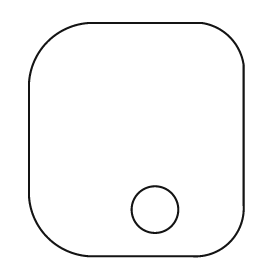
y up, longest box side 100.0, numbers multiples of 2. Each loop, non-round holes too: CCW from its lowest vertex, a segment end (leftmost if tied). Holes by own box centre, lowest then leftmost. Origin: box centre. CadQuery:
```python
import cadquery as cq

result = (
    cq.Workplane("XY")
    .moveTo(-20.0, -50.0)
    .lineTo(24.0, -50.0)
    .threePointArc((40.0, -44.0), (46.0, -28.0))
    .lineTo(46.0, 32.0)
    .threePointArc((40.0, 44.0), (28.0, 50.0))
    .lineTo(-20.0, 50.0)
    .threePointArc((-38.0, 42.0), (-46.0, 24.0))
    .lineTo(-46.0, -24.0)
    .threePointArc((-38.0, -42.0), (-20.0, -50.0))
    .close()
    .moveTo(8.0, -30.0)
    .circle(10.0)
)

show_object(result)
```